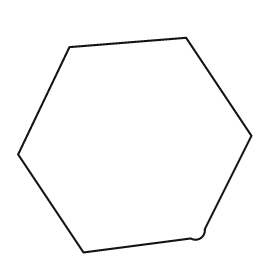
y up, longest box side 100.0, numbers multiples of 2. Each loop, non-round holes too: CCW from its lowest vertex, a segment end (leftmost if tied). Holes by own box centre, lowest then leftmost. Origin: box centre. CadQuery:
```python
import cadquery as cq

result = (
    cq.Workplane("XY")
    .moveTo(-22.0, -46.0)
    .lineTo(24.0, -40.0)
    .threePointArc((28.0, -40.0), (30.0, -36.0))
    .lineTo(50.0, 4.0)
    .lineTo(22.0, 46.0)
    .lineTo(-28.0, 42.0)
    .lineTo(-50.0, -4.0)
    .close()
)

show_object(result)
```